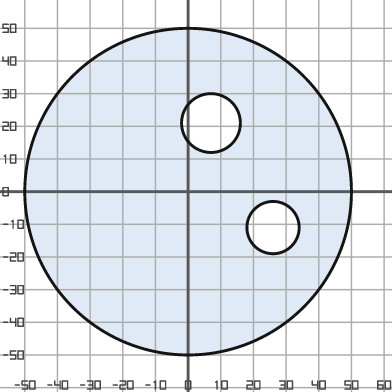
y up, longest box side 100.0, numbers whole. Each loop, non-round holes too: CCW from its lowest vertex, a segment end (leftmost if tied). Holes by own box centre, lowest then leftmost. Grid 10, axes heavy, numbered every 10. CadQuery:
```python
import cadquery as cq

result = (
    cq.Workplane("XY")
    .moveTo(0.0, 0.0)
    .circle(50.0)
    .moveTo(26.0, -11.0)
    .circle(8.0)
    .moveTo(7.0, 21.0)
    .circle(9.0)
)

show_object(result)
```